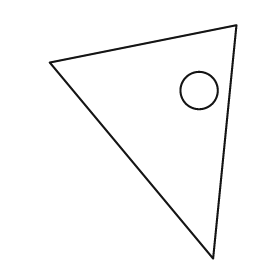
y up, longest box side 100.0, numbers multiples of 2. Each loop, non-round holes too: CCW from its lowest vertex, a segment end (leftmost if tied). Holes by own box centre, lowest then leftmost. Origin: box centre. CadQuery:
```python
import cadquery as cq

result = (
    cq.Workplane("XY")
    .moveTo(30.0, -50.0)
    .lineTo(40.0, 50.0)
    .lineTo(-40.0, 34.0)
    .close()
    .moveTo(24.0, 22.0)
    .circle(8.0)
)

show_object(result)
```